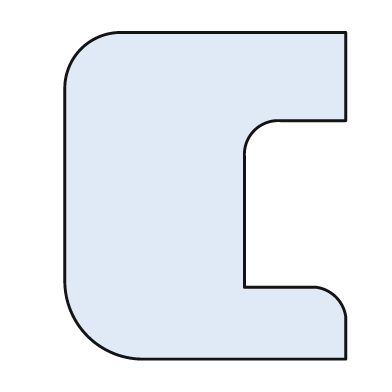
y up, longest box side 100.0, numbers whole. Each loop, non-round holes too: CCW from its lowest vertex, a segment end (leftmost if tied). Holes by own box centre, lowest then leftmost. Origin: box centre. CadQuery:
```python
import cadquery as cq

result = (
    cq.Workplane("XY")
    .moveTo(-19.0, -50.0)
    .lineTo(43.0, -50.0)
    .lineTo(43.0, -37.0)
    .threePointArc((40.0, -31.0), (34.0, -28.0))
    .lineTo(12.0, -28.0)
    .lineTo(12.0, 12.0)
    .threePointArc((15.0, 20.0), (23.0, 23.0))
    .lineTo(43.0, 23.0)
    .lineTo(43.0, 50.0)
    .lineTo(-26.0, 50.0)
    .threePointArc((-38.0, 45.0), (-43.0, 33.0))
    .lineTo(-43.0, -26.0)
    .threePointArc((-36.0, -43.0), (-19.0, -50.0))
    .close()
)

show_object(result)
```